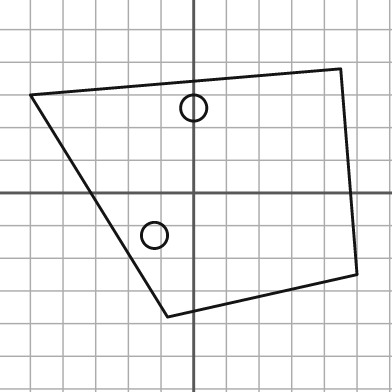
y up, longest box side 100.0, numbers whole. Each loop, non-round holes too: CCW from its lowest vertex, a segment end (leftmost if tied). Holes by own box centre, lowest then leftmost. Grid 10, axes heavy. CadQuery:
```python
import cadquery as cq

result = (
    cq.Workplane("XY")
    .moveTo(-8.0, -38.0)
    .lineTo(50.0, -25.0)
    .lineTo(45.0, 38.0)
    .lineTo(-50.0, 30.0)
    .close()
    .moveTo(-12.0, -13.0)
    .circle(4.0)
    .moveTo(0.0, 26.0)
    .circle(4.0)
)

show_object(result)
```